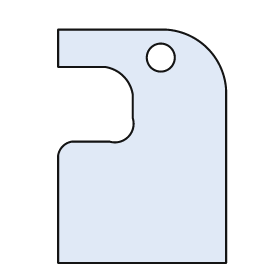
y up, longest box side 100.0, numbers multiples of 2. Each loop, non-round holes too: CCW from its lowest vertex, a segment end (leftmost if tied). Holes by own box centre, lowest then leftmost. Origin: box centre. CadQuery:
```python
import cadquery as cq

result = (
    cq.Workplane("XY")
    .moveTo(-36.0, -50.0)
    .lineTo(36.0, -50.0)
    .lineTo(36.0, 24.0)
    .threePointArc((28.0, 42.0), (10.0, 50.0))
    .lineTo(-36.0, 50.0)
    .lineTo(-36.0, 34.0)
    .lineTo(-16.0, 34.0)
    .threePointArc((-8.0, 30.0), (-4.0, 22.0))
    .lineTo(-4.0, 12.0)
    .threePointArc((-6.0, 4.0), (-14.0, 2.0))
    .lineTo(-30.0, 2.0)
    .threePointArc((-34.0, 0.0), (-36.0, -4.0))
    .close()
    .moveTo(8.0, 38.0)
    .circle(6.0)
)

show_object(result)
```